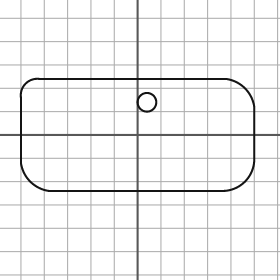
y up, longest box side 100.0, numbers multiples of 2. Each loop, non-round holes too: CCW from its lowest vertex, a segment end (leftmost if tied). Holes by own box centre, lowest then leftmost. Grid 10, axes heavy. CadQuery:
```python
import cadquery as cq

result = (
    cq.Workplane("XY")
    .moveTo(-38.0, -24.0)
    .lineTo(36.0, -24.0)
    .threePointArc((46.0, -20.0), (50.0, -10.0))
    .lineTo(50.0, 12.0)
    .threePointArc((46.0, 20.0), (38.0, 24.0))
    .lineTo(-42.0, 24.0)
    .threePointArc((-48.0, 22.0), (-50.0, 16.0))
    .lineTo(-50.0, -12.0)
    .threePointArc((-46.0, -20.0), (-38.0, -24.0))
    .close()
    .moveTo(4.0, 14.0)
    .circle(4.0)
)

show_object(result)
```